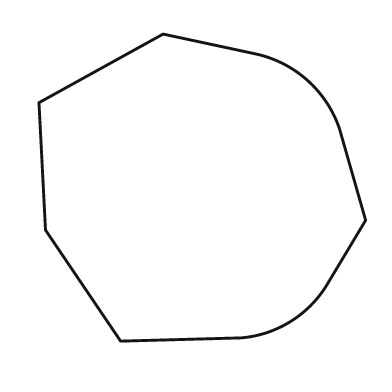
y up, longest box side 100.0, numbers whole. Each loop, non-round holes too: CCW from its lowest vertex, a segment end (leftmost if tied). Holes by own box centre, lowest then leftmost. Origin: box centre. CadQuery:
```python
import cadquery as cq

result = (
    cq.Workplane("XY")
    .moveTo(-25.0, -47.0)
    .lineTo(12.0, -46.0)
    .threePointArc((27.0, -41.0), (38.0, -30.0))
    .lineTo(50.0, -10.0)
    .lineTo(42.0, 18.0)
    .threePointArc((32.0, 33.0), (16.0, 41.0))
    .lineTo(-12.0, 47.0)
    .lineTo(-50.0, 26.0)
    .lineTo(-48.0, -13.0)
    .close()
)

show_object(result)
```